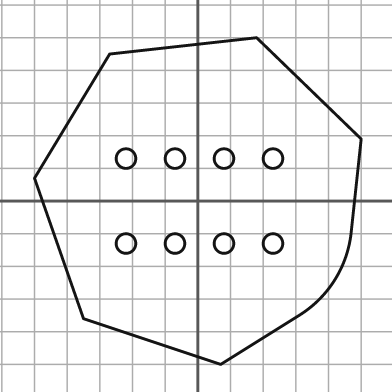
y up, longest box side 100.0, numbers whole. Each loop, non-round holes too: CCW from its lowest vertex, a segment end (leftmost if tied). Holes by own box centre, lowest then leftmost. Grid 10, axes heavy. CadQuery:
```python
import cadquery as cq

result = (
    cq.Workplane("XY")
    .moveTo(7.0, -50.0)
    .lineTo(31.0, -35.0)
    .threePointArc((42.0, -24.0), (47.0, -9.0))
    .lineTo(50.0, 19.0)
    .lineTo(18.0, 50.0)
    .lineTo(-27.0, 45.0)
    .lineTo(-50.0, 7.0)
    .lineTo(-35.0, -36.0)
    .close()
    .moveTo(-22.0, -13.0)
    .circle(3.0)
    .moveTo(-7.0, -13.0)
    .circle(3.0)
    .moveTo(8.0, -13.0)
    .circle(3.0)
    .moveTo(23.0, -13.0)
    .circle(3.0)
    .moveTo(-22.0, 13.0)
    .circle(3.0)
    .moveTo(-7.0, 13.0)
    .circle(3.0)
    .moveTo(8.0, 13.0)
    .circle(3.0)
    .moveTo(23.0, 13.0)
    .circle(3.0)
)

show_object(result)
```